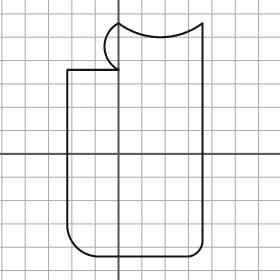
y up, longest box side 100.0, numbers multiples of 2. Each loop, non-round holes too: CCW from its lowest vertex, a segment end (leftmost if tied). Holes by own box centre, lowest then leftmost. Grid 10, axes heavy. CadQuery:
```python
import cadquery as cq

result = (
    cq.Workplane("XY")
    .moveTo(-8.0, -44.0)
    .lineTo(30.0, -44.0)
    .threePointArc((34.0, -42.0), (36.0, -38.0))
    .lineTo(36.0, 56.0)
    .threePointArc((18.0, 50.0), (0.0, 56.0))
    .threePointArc((-6.0, 46.0), (0.0, 36.0))
    .lineTo(-22.0, 36.0)
    .lineTo(-22.0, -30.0)
    .threePointArc((-18.0, -40.0), (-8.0, -44.0))
    .close()
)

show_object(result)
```